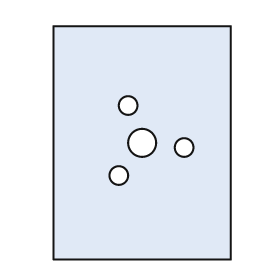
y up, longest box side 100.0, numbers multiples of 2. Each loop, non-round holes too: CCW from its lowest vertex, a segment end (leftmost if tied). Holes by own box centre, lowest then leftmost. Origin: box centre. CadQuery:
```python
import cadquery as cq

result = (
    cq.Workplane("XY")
    .moveTo(-38.0, -50.0)
    .lineTo(38.0, -50.0)
    .lineTo(38.0, 50.0)
    .lineTo(-38.0, 50.0)
    .close()
    .moveTo(-10.0, -14.0)
    .circle(4.0)
    .moveTo(18.0, -2.0)
    .circle(4.0)
    .moveTo(0.0, 0.0)
    .circle(6.0)
    .moveTo(-6.0, 16.0)
    .circle(4.0)
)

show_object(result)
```